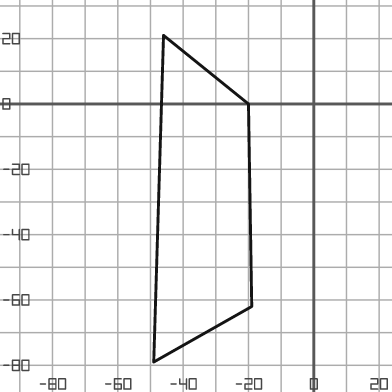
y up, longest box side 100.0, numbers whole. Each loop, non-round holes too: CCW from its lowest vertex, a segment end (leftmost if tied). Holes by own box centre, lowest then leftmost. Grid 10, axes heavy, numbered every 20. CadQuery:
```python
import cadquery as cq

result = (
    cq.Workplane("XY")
    .moveTo(-49.0, -79.0)
    .lineTo(-19.0, -62.0)
    .lineTo(-20.0, 0.0)
    .lineTo(-46.0, 21.0)
    .close()
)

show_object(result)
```